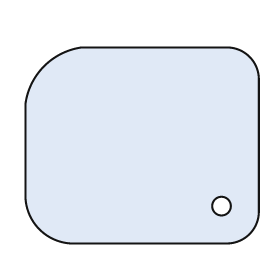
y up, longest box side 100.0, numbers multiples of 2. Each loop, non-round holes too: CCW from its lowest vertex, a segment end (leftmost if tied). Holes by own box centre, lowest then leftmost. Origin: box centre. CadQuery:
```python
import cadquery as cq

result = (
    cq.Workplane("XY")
    .moveTo(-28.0, -42.0)
    .lineTo(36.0, -42.0)
    .threePointArc((46.0, -38.0), (50.0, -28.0))
    .lineTo(50.0, 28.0)
    .threePointArc((46.0, 38.0), (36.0, 42.0))
    .lineTo(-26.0, 42.0)
    .threePointArc((-42.0, 34.0), (-50.0, 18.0))
    .lineTo(-50.0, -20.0)
    .threePointArc((-44.0, -36.0), (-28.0, -42.0))
    .close()
    .moveTo(34.0, -26.0)
    .circle(4.0)
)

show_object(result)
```